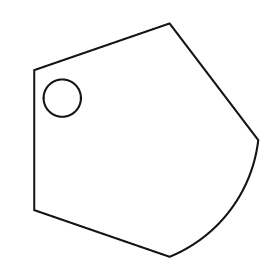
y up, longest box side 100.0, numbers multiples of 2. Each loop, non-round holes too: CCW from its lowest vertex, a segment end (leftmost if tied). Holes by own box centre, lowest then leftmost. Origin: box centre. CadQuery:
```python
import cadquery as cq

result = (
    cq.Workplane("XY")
    .moveTo(10.0, -50.0)
    .threePointArc((36.0, -30.0), (48.0, 0.0))
    .lineTo(10.0, 50.0)
    .lineTo(-48.0, 30.0)
    .lineTo(-48.0, -30.0)
    .close()
    .moveTo(-36.0, 18.0)
    .circle(8.0)
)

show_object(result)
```